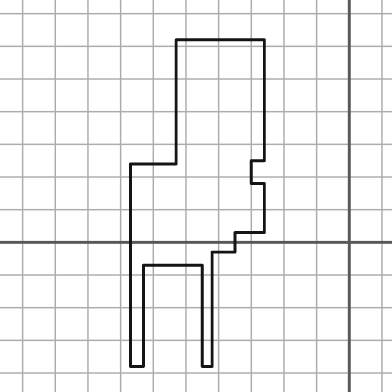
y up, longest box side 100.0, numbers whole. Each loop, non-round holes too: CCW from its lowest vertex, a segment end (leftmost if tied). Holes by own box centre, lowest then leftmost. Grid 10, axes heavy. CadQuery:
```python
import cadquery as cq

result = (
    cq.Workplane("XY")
    .moveTo(-67.0, -38.0)
    .lineTo(-63.0, -38.0)
    .lineTo(-63.0, -7.0)
    .lineTo(-45.0, -7.0)
    .lineTo(-45.0, -38.0)
    .lineTo(-42.0, -38.0)
    .lineTo(-42.0, -3.0)
    .lineTo(-35.0, -3.0)
    .lineTo(-35.0, 3.0)
    .lineTo(-26.0, 3.0)
    .lineTo(-26.0, 18.0)
    .lineTo(-30.0, 18.0)
    .lineTo(-30.0, 25.0)
    .lineTo(-26.0, 25.0)
    .lineTo(-26.0, 62.0)
    .lineTo(-53.0, 62.0)
    .lineTo(-53.0, 24.0)
    .lineTo(-67.0, 24.0)
    .close()
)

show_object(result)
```